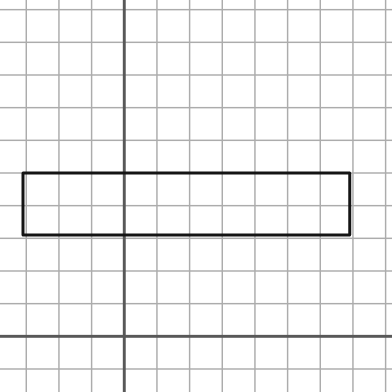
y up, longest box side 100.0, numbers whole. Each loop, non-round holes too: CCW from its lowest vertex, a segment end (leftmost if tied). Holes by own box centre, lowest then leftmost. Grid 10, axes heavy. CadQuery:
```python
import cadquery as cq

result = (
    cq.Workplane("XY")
    .moveTo(-31.0, 31.0)
    .lineTo(69.0, 31.0)
    .lineTo(69.0, 50.0)
    .lineTo(-31.0, 50.0)
    .close()
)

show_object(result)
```